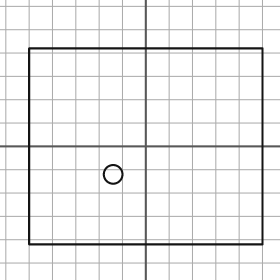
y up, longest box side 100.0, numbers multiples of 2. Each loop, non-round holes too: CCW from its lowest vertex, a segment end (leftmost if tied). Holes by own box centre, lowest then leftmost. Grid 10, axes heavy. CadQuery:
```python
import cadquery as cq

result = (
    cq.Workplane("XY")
    .moveTo(-50.0, -42.0)
    .lineTo(50.0, -42.0)
    .lineTo(50.0, 42.0)
    .lineTo(-50.0, 42.0)
    .close()
    .moveTo(-14.0, -12.0)
    .circle(4.0)
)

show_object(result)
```